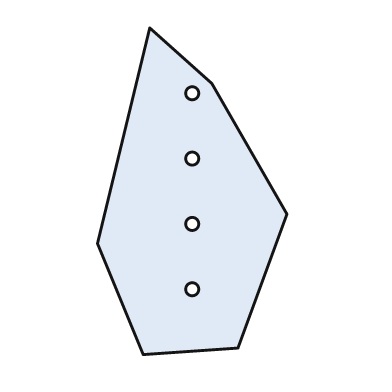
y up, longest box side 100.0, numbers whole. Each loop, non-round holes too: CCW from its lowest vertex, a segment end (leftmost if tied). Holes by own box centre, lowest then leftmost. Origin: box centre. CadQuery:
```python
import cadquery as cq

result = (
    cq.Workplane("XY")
    .moveTo(-15.0, -50.0)
    .lineTo(14.0, -48.0)
    .lineTo(29.0, -7.0)
    .lineTo(6.0, 33.0)
    .lineTo(-13.0, 50.0)
    .lineTo(-29.0, -16.0)
    .close()
    .moveTo(0.0, -30.0)
    .circle(2.0)
    .moveTo(0.0, -10.0)
    .circle(2.0)
    .moveTo(0.0, 10.0)
    .circle(2.0)
    .moveTo(0.0, 30.0)
    .circle(2.0)
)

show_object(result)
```